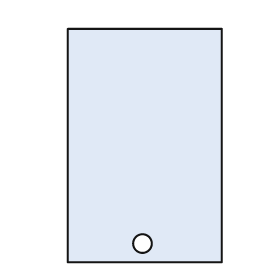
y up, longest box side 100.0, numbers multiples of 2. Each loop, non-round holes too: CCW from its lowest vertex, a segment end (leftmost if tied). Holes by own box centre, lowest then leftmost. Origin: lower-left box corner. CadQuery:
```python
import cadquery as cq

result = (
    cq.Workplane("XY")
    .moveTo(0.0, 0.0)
    .lineTo(66.0, 0.0)
    .lineTo(66.0, 100.0)
    .lineTo(0.0, 100.0)
    .close()
    .moveTo(32.0, 8.0)
    .circle(4.0)
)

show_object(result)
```